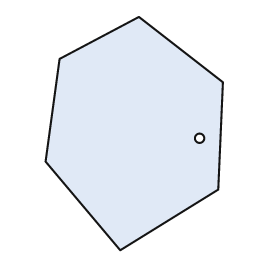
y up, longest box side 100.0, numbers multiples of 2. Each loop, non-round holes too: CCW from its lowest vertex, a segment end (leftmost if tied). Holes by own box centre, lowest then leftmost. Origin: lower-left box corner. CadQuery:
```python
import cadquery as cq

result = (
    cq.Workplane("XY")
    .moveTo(32.0, 0.0)
    .lineTo(74.0, 26.0)
    .lineTo(76.0, 72.0)
    .lineTo(40.0, 100.0)
    .lineTo(6.0, 82.0)
    .lineTo(0.0, 38.0)
    .close()
    .moveTo(66.0, 48.0)
    .circle(2.0)
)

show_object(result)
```